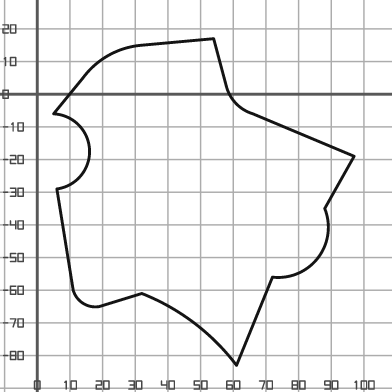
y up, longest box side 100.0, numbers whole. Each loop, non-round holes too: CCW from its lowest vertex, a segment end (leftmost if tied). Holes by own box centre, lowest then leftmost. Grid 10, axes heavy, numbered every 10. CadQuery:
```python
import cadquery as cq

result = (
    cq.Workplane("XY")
    .moveTo(61.0, -83.0)
    .lineTo(72.0, -56.0)
    .threePointArc((86.0, -50.0), (88.0, -35.0))
    .lineTo(97.0, -19.0)
    .lineTo(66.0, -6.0)
    .threePointArc((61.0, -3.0), (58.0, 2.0))
    .lineTo(54.0, 17.0)
    .lineTo(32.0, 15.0)
    .threePointArc((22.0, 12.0), (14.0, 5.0))
    .lineTo(5.0, -6.0)
    .threePointArc((16.0, -17.0), (6.0, -29.0))
    .lineTo(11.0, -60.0)
    .threePointArc((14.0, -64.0), (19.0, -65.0))
    .lineTo(32.0, -61.0)
    .threePointArc((48.0, -70.0), (61.0, -83.0))
    .close()
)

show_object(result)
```